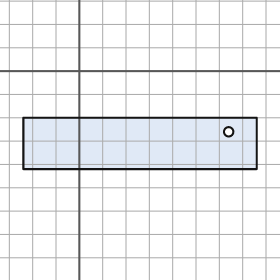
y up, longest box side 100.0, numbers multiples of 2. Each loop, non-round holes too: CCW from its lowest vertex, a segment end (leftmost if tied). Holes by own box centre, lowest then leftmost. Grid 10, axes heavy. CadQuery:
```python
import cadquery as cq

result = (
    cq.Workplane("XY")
    .moveTo(-24.0, -42.0)
    .lineTo(76.0, -42.0)
    .lineTo(76.0, -20.0)
    .lineTo(-24.0, -20.0)
    .close()
    .moveTo(64.0, -26.0)
    .circle(2.0)
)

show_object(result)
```